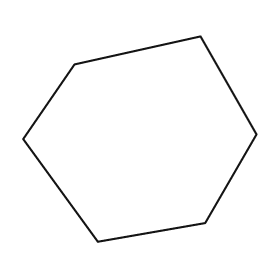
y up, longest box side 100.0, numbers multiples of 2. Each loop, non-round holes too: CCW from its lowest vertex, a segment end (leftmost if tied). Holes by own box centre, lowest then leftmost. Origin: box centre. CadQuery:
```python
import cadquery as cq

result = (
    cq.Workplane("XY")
    .moveTo(-18.0, -44.0)
    .lineTo(28.0, -36.0)
    .lineTo(50.0, 2.0)
    .lineTo(26.0, 44.0)
    .lineTo(-28.0, 32.0)
    .lineTo(-50.0, 0.0)
    .close()
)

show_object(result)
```